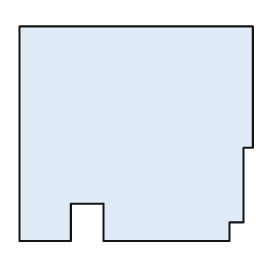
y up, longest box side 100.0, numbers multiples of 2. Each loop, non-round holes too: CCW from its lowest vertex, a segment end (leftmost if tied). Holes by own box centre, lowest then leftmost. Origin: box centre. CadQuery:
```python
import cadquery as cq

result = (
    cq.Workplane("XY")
    .moveTo(-50.0, -46.0)
    .lineTo(-28.0, -46.0)
    .lineTo(-28.0, -30.0)
    .lineTo(-14.0, -30.0)
    .lineTo(-14.0, -46.0)
    .lineTo(40.0, -46.0)
    .lineTo(40.0, -38.0)
    .lineTo(46.0, -38.0)
    .lineTo(46.0, -6.0)
    .lineTo(50.0, -6.0)
    .lineTo(50.0, 46.0)
    .lineTo(-50.0, 46.0)
    .close()
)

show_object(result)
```